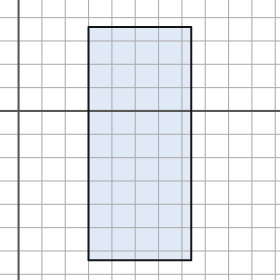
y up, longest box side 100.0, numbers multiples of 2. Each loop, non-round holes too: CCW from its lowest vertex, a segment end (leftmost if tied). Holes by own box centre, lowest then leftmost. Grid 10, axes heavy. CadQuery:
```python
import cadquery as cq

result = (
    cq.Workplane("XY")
    .moveTo(30.0, -64.0)
    .lineTo(74.0, -64.0)
    .lineTo(74.0, 36.0)
    .lineTo(30.0, 36.0)
    .close()
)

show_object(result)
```